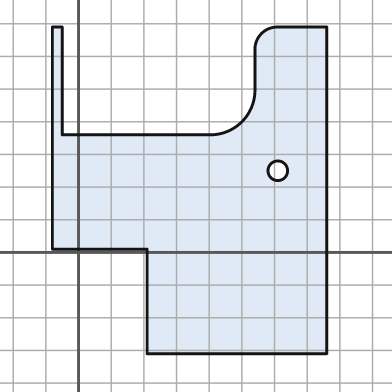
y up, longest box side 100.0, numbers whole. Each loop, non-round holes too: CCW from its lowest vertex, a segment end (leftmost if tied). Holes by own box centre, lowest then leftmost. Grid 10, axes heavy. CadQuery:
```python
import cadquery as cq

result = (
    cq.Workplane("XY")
    .moveTo(21.0, -31.0)
    .lineTo(76.0, -31.0)
    .lineTo(76.0, 69.0)
    .lineTo(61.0, 69.0)
    .threePointArc((56.0, 67.0), (54.0, 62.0))
    .lineTo(54.0, 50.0)
    .threePointArc((50.0, 40.0), (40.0, 36.0))
    .lineTo(-5.0, 36.0)
    .lineTo(-5.0, 69.0)
    .lineTo(-8.0, 69.0)
    .lineTo(-8.0, 1.0)
    .lineTo(21.0, 1.0)
    .close()
    .moveTo(61.0, 25.0)
    .circle(3.0)
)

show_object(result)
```